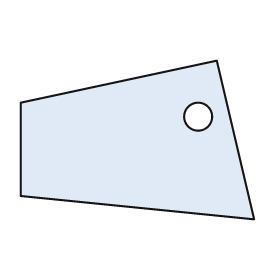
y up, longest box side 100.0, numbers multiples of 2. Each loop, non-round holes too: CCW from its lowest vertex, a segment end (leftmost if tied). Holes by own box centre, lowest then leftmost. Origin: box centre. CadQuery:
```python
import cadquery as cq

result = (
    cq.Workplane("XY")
    .moveTo(50.0, -34.0)
    .lineTo(34.0, 34.0)
    .lineTo(-50.0, 16.0)
    .lineTo(-50.0, -24.0)
    .close()
    .moveTo(26.0, 10.0)
    .circle(6.0)
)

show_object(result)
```